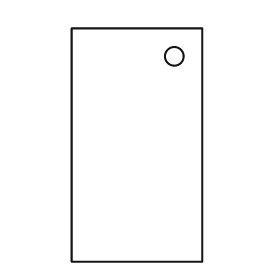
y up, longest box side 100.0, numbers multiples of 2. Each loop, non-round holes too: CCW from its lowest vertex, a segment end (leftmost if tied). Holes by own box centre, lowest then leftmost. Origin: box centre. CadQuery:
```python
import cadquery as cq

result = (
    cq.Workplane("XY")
    .moveTo(-28.0, -50.0)
    .lineTo(28.0, -50.0)
    .lineTo(28.0, 50.0)
    .lineTo(-28.0, 50.0)
    .close()
    .moveTo(16.0, 38.0)
    .circle(4.0)
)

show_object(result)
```